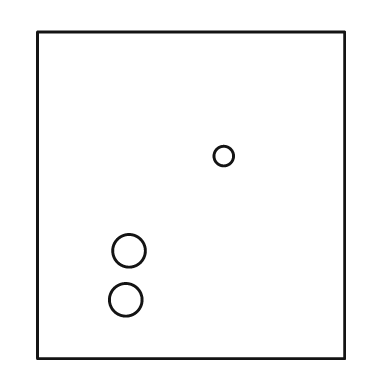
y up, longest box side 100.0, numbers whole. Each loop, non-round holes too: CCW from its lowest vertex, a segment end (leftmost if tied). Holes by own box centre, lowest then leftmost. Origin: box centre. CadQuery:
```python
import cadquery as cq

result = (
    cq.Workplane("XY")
    .moveTo(-47.0, -50.0)
    .lineTo(47.0, -50.0)
    .lineTo(47.0, 50.0)
    .lineTo(-47.0, 50.0)
    .close()
    .moveTo(-20.0, -32.0)
    .circle(5.0)
    .moveTo(-19.0, -17.0)
    .circle(5.0)
    .moveTo(10.0, 12.0)
    .circle(3.0)
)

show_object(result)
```